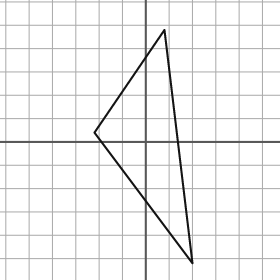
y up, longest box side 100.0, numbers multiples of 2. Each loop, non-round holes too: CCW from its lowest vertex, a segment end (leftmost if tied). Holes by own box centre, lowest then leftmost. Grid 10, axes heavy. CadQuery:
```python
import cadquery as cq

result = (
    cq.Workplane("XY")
    .moveTo(20.0, -52.0)
    .lineTo(8.0, 48.0)
    .lineTo(-22.0, 4.0)
    .close()
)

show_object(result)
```